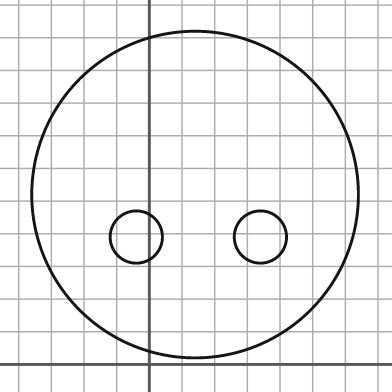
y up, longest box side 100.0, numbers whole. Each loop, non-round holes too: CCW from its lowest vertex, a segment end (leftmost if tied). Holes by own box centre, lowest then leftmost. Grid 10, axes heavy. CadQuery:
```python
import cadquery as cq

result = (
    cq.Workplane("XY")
    .moveTo(14.0, 52.0)
    .circle(50.0)
    .moveTo(-4.0, 39.0)
    .circle(8.0)
    .moveTo(34.0, 39.0)
    .circle(8.0)
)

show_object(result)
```